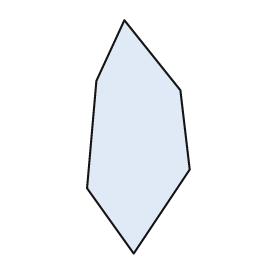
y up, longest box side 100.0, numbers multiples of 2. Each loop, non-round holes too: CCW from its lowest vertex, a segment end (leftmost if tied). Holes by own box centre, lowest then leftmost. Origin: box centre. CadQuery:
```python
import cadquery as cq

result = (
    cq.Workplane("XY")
    .moveTo(-2.0, -50.0)
    .lineTo(22.0, -14.0)
    .lineTo(18.0, 20.0)
    .lineTo(-6.0, 50.0)
    .lineTo(-18.0, 24.0)
    .lineTo(-22.0, -22.0)
    .close()
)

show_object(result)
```